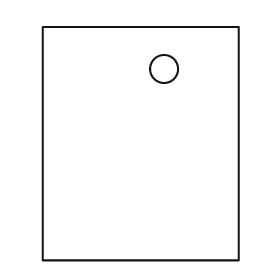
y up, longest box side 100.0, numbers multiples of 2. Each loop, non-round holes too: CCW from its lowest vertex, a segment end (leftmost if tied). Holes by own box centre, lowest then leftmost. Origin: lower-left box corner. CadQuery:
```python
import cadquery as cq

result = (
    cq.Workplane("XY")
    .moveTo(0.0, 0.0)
    .lineTo(84.0, 0.0)
    .lineTo(84.0, 100.0)
    .lineTo(0.0, 100.0)
    .close()
    .moveTo(52.0, 82.0)
    .circle(6.0)
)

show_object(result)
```